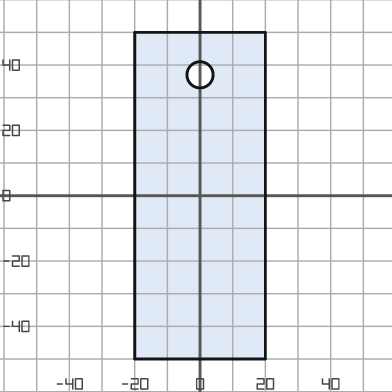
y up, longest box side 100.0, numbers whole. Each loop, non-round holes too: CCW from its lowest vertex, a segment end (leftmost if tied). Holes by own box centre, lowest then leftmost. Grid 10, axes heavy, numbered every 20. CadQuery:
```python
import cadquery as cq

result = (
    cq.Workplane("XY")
    .moveTo(-20.0, -50.0)
    .lineTo(20.0, -50.0)
    .lineTo(20.0, 50.0)
    .lineTo(-20.0, 50.0)
    .close()
    .moveTo(0.0, 37.0)
    .circle(4.0)
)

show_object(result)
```